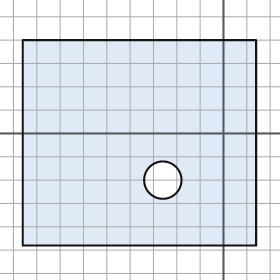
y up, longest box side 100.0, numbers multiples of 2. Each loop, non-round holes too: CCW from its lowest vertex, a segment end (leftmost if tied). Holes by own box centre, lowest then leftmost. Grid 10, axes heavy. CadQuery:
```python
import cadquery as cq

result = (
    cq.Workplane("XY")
    .moveTo(-86.0, -48.0)
    .lineTo(14.0, -48.0)
    .lineTo(14.0, 40.0)
    .lineTo(-86.0, 40.0)
    .close()
    .moveTo(-26.0, -20.0)
    .circle(8.0)
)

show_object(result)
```